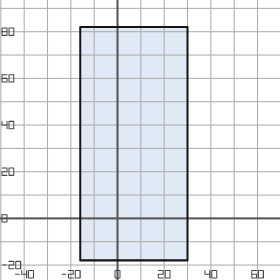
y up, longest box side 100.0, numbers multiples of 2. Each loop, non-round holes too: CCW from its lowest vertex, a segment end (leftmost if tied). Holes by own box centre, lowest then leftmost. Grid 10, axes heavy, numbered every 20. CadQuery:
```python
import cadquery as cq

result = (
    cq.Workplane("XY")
    .moveTo(-16.0, -18.0)
    .lineTo(30.0, -18.0)
    .lineTo(30.0, 82.0)
    .lineTo(-16.0, 82.0)
    .close()
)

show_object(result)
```